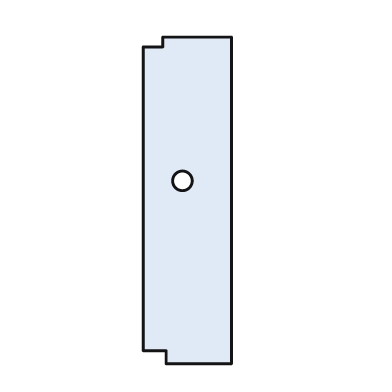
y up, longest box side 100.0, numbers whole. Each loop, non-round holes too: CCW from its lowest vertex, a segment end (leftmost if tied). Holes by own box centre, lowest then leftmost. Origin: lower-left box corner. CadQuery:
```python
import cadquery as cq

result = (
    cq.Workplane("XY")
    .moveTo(7.0, 0.0)
    .lineTo(27.0, 0.0)
    .lineTo(27.0, 100.0)
    .lineTo(6.0, 100.0)
    .lineTo(6.0, 97.0)
    .lineTo(0.0, 97.0)
    .lineTo(0.0, 4.0)
    .lineTo(7.0, 4.0)
    .close()
    .moveTo(12.0, 56.0)
    .circle(3.0)
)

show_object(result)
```